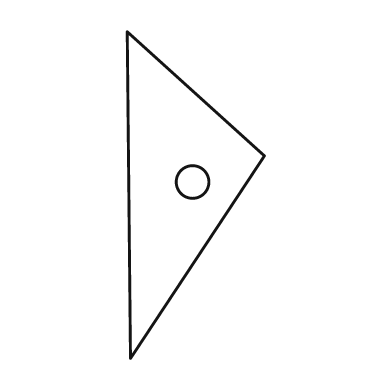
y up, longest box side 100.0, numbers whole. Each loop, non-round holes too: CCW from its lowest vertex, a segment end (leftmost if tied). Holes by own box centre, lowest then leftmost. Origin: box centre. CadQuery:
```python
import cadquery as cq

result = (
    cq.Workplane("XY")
    .moveTo(-20.0, -50.0)
    .lineTo(21.0, 12.0)
    .lineTo(-21.0, 50.0)
    .close()
    .moveTo(-1.0, 4.0)
    .circle(5.0)
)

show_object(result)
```